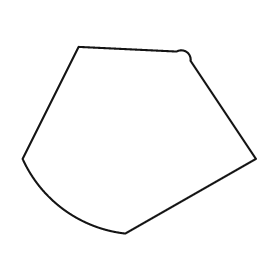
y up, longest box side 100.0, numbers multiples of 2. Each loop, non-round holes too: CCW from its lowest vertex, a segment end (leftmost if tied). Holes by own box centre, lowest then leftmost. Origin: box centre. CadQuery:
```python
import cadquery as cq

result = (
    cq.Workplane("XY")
    .moveTo(-6.0, -40.0)
    .lineTo(50.0, -8.0)
    .lineTo(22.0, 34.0)
    .threePointArc((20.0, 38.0), (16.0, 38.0))
    .lineTo(-26.0, 40.0)
    .lineTo(-50.0, -8.0)
    .threePointArc((-32.0, -30.0), (-6.0, -40.0))
    .close()
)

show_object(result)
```